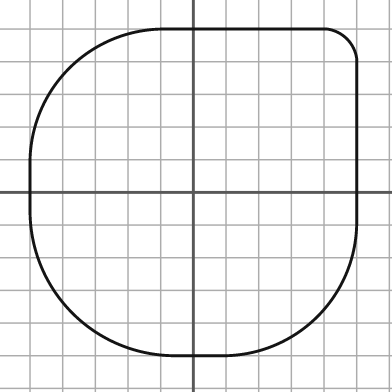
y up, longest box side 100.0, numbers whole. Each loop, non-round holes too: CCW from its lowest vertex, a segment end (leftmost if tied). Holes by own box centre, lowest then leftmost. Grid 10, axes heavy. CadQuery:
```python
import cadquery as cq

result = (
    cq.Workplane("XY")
    .moveTo(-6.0, -50.0)
    .lineTo(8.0, -50.0)
    .threePointArc((38.0, -38.0), (50.0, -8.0))
    .lineTo(50.0, 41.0)
    .threePointArc((47.0, 47.0), (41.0, 50.0))
    .lineTo(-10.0, 50.0)
    .threePointArc((-38.0, 38.0), (-50.0, 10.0))
    .lineTo(-50.0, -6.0)
    .threePointArc((-37.0, -37.0), (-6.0, -50.0))
    .close()
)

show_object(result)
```